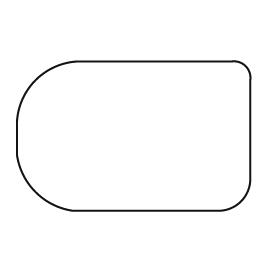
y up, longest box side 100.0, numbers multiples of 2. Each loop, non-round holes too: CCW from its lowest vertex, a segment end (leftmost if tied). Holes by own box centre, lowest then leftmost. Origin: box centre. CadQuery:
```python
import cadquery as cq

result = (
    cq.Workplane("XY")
    .moveTo(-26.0, -32.0)
    .lineTo(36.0, -32.0)
    .threePointArc((46.0, -28.0), (50.0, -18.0))
    .lineTo(50.0, 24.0)
    .threePointArc((48.0, 30.0), (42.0, 32.0))
    .lineTo(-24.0, 32.0)
    .threePointArc((-42.0, 24.0), (-50.0, 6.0))
    .lineTo(-50.0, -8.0)
    .threePointArc((-42.0, -24.0), (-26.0, -32.0))
    .close()
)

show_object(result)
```